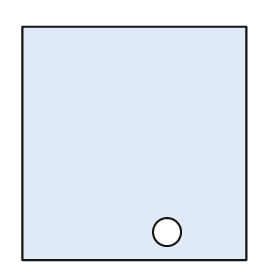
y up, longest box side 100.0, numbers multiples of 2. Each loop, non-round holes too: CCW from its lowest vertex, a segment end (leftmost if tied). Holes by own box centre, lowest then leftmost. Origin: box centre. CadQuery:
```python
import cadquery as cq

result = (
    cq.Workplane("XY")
    .moveTo(-48.0, -50.0)
    .lineTo(48.0, -50.0)
    .lineTo(48.0, 50.0)
    .lineTo(-48.0, 50.0)
    .close()
    .moveTo(14.0, -38.0)
    .circle(6.0)
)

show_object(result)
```